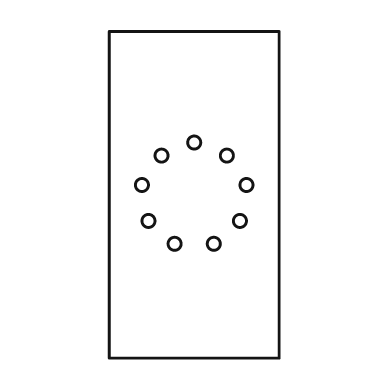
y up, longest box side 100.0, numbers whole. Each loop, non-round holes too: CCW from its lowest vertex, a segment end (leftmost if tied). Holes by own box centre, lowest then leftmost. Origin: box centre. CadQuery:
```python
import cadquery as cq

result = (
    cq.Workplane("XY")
    .moveTo(-26.0, -50.0)
    .lineTo(26.0, -50.0)
    .lineTo(26.0, 50.0)
    .lineTo(-26.0, 50.0)
    .close()
    .moveTo(-6.0, -15.0)
    .circle(2.0)
    .moveTo(6.0, -15.0)
    .circle(2.0)
    .moveTo(-14.0, -8.0)
    .circle(2.0)
    .moveTo(14.0, -8.0)
    .circle(2.0)
    .moveTo(-16.0, 3.0)
    .circle(2.0)
    .moveTo(16.0, 3.0)
    .circle(2.0)
    .moveTo(-10.0, 12.0)
    .circle(2.0)
    .moveTo(10.0, 12.0)
    .circle(2.0)
    .moveTo(0.0, 16.0)
    .circle(2.0)
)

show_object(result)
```